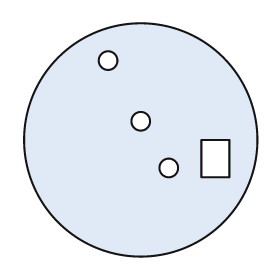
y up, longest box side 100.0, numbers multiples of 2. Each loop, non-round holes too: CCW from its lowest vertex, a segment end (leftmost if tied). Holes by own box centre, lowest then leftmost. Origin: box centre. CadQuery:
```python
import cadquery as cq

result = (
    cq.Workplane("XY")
    .moveTo(0.0, 0.0)
    .circle(50.0)
    .moveTo(12.0, -12.0)
    .circle(4.0)
    .moveTo(26.0, -16.0)
    .lineTo(38.0, -16.0)
    .lineTo(38.0, 0.0)
    .lineTo(26.0, 0.0)
    .close()
    .moveTo(0.0, 8.0)
    .circle(4.0)
    .moveTo(-14.0, 34.0)
    .circle(4.0)
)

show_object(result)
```